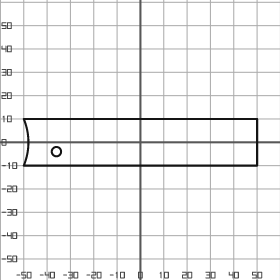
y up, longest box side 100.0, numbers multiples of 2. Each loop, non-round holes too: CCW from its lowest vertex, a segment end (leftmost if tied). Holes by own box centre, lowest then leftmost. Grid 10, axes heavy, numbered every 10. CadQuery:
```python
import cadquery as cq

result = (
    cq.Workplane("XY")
    .moveTo(-50.0, -10.0)
    .lineTo(50.0, -10.0)
    .lineTo(50.0, 10.0)
    .lineTo(-50.0, 10.0)
    .threePointArc((-48.0, 0.0), (-50.0, -10.0))
    .close()
    .moveTo(-36.0, -4.0)
    .circle(2.0)
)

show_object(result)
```